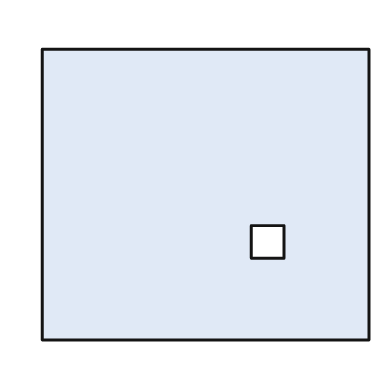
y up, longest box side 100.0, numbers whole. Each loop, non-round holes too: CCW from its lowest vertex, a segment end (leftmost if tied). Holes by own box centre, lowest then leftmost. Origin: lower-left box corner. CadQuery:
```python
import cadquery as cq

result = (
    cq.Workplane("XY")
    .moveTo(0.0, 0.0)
    .lineTo(100.0, 0.0)
    .lineTo(100.0, 89.0)
    .lineTo(0.0, 89.0)
    .close()
    .moveTo(64.0, 25.0)
    .lineTo(74.0, 25.0)
    .lineTo(74.0, 35.0)
    .lineTo(64.0, 35.0)
    .close()
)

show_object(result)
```